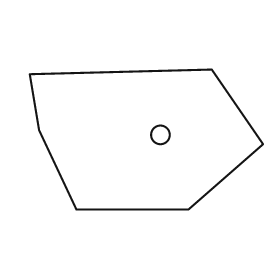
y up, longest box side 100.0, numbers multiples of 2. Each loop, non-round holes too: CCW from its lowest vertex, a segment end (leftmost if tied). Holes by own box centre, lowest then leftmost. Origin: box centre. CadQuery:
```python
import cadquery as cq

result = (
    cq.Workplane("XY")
    .moveTo(-30.0, -30.0)
    .lineTo(18.0, -30.0)
    .lineTo(50.0, -2.0)
    .lineTo(28.0, 30.0)
    .lineTo(-50.0, 28.0)
    .lineTo(-46.0, 4.0)
    .close()
    .moveTo(6.0, 2.0)
    .circle(4.0)
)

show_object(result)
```